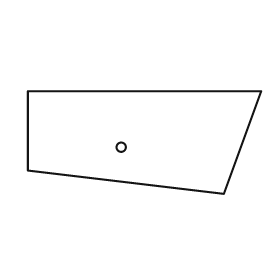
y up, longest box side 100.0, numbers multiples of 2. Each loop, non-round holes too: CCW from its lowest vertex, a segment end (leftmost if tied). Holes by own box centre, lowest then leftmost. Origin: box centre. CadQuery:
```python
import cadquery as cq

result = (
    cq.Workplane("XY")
    .moveTo(34.0, -22.0)
    .lineTo(50.0, 22.0)
    .lineTo(-50.0, 22.0)
    .lineTo(-50.0, -12.0)
    .close()
    .moveTo(-10.0, -2.0)
    .circle(2.0)
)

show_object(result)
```